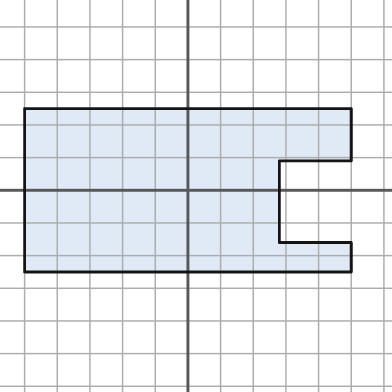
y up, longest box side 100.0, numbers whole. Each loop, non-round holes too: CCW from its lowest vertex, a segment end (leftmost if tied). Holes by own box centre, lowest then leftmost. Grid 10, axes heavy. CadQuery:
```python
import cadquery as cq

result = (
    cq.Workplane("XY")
    .moveTo(-50.0, -25.0)
    .lineTo(50.0, -25.0)
    .lineTo(50.0, -16.0)
    .lineTo(28.0, -16.0)
    .lineTo(28.0, 9.0)
    .lineTo(50.0, 9.0)
    .lineTo(50.0, 25.0)
    .lineTo(-50.0, 25.0)
    .close()
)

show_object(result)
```